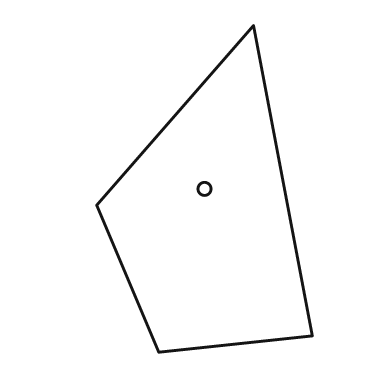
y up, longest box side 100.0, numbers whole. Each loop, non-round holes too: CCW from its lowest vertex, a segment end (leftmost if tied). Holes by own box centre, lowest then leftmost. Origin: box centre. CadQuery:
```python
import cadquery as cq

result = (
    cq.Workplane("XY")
    .moveTo(-14.0, -50.0)
    .lineTo(33.0, -45.0)
    .lineTo(15.0, 50.0)
    .lineTo(-33.0, -5.0)
    .close()
    .moveTo(0.0, 0.0)
    .circle(2.0)
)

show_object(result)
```